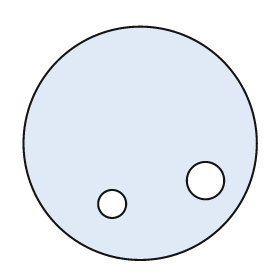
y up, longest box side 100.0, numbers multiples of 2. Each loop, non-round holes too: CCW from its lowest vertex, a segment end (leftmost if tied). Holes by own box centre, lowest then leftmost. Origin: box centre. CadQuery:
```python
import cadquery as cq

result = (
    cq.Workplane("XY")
    .moveTo(0.0, 0.0)
    .circle(50.0)
    .moveTo(-12.0, -26.0)
    .circle(6.0)
    .moveTo(28.0, -16.0)
    .circle(8.0)
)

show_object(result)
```